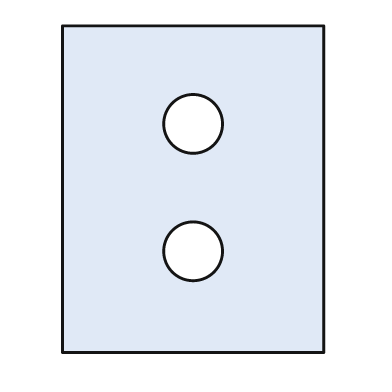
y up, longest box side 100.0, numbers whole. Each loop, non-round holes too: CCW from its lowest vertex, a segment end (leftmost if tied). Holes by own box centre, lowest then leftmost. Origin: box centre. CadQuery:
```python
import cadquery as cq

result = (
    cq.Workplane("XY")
    .moveTo(-40.0, -50.0)
    .lineTo(40.0, -50.0)
    .lineTo(40.0, 50.0)
    .lineTo(-40.0, 50.0)
    .close()
    .moveTo(0.0, -19.0)
    .circle(9.0)
    .moveTo(0.0, 20.0)
    .circle(9.0)
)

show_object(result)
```